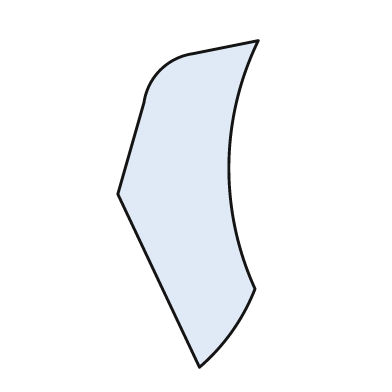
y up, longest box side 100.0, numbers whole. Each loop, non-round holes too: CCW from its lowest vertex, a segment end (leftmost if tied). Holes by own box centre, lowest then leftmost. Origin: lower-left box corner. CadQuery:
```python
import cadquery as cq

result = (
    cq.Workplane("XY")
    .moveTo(25.0, 0.0)
    .threePointArc((35.0, 11.0), (42.0, 24.0))
    .threePointArc((34.0, 62.0), (43.0, 100.0))
    .lineTo(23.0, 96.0)
    .threePointArc((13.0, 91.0), (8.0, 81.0))
    .lineTo(0.0, 53.0)
    .close()
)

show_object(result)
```